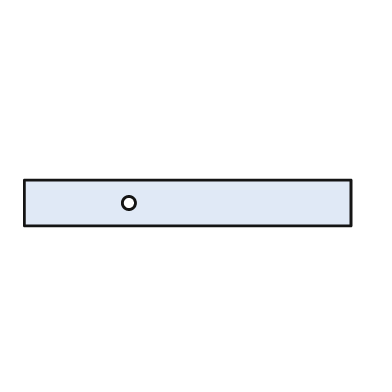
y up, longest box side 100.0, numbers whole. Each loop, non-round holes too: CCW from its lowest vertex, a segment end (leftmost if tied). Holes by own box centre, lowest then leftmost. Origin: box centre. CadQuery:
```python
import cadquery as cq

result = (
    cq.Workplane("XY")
    .moveTo(-50.0, -7.0)
    .lineTo(50.0, -7.0)
    .lineTo(50.0, 7.0)
    .lineTo(-50.0, 7.0)
    .close()
    .moveTo(-18.0, 0.0)
    .circle(2.0)
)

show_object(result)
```